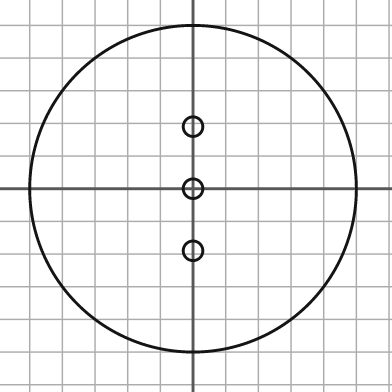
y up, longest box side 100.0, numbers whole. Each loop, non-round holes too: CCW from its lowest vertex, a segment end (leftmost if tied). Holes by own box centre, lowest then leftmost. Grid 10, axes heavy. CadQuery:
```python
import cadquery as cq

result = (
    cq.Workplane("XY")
    .moveTo(0.0, 0.0)
    .circle(50.0)
    .moveTo(0.0, -19.0)
    .circle(3.0)
    .moveTo(0.0, 0.0)
    .circle(3.0)
    .moveTo(0.0, 19.0)
    .circle(3.0)
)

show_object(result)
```